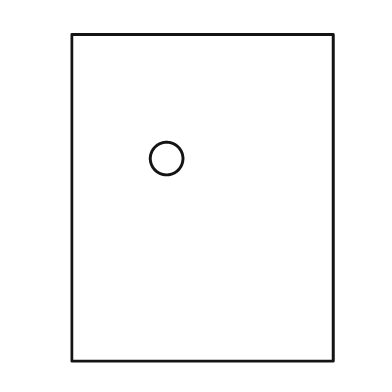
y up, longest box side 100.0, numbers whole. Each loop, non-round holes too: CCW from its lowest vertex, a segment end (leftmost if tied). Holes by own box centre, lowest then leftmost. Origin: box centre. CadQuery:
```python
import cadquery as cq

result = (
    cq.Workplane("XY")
    .moveTo(-40.0, -50.0)
    .lineTo(40.0, -50.0)
    .lineTo(40.0, 50.0)
    .lineTo(-40.0, 50.0)
    .close()
    .moveTo(-11.0, 12.0)
    .circle(5.0)
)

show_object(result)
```